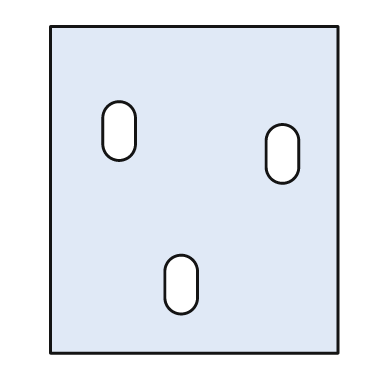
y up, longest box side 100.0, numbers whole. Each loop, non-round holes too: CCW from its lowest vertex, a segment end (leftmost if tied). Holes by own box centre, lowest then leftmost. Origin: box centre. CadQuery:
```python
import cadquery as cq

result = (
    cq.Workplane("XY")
    .moveTo(-44.0, -50.0)
    .lineTo(44.0, -50.0)
    .lineTo(44.0, 50.0)
    .lineTo(-44.0, 50.0)
    .close()
    .moveTo(-9.0, -33.0)
    .threePointArc((-4.0, -38.0), (1.0, -33.0))
    .lineTo(1.0, -25.0)
    .threePointArc((-4.0, -20.0), (-9.0, -25.0))
    .close()
    .moveTo(22.0, 7.0)
    .threePointArc((27.0, 2.0), (32.0, 7.0))
    .lineTo(32.0, 15.0)
    .threePointArc((27.0, 20.0), (22.0, 15.0))
    .close()
    .moveTo(-28.0, 14.0)
    .threePointArc((-23.0, 9.0), (-18.0, 14.0))
    .lineTo(-18.0, 22.0)
    .threePointArc((-23.0, 27.0), (-28.0, 22.0))
    .close()
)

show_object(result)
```